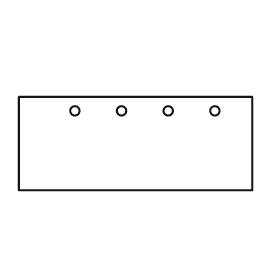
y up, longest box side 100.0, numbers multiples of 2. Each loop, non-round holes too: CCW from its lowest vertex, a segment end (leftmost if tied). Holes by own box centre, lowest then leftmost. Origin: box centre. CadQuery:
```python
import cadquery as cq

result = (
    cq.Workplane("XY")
    .moveTo(-50.0, -20.0)
    .lineTo(50.0, -20.0)
    .lineTo(50.0, 20.0)
    .lineTo(-50.0, 20.0)
    .close()
    .moveTo(-26.0, 14.0)
    .circle(2.0)
    .moveTo(-6.0, 14.0)
    .circle(2.0)
    .moveTo(14.0, 14.0)
    .circle(2.0)
    .moveTo(34.0, 14.0)
    .circle(2.0)
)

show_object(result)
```